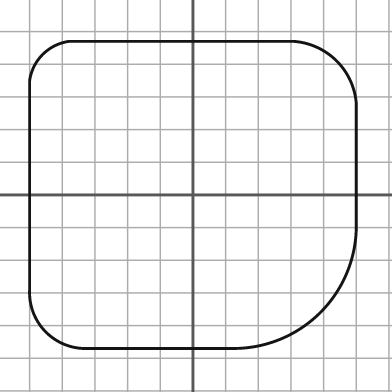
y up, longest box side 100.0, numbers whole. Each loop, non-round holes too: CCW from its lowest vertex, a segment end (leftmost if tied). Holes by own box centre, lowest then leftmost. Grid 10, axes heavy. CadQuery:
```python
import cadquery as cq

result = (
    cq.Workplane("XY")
    .moveTo(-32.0, -47.0)
    .lineTo(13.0, -47.0)
    .threePointArc((39.0, -36.0), (50.0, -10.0))
    .lineTo(50.0, 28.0)
    .threePointArc((44.0, 41.0), (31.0, 47.0))
    .lineTo(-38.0, 47.0)
    .threePointArc((-46.0, 43.0), (-50.0, 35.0))
    .lineTo(-50.0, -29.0)
    .threePointArc((-45.0, -42.0), (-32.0, -47.0))
    .close()
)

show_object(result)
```